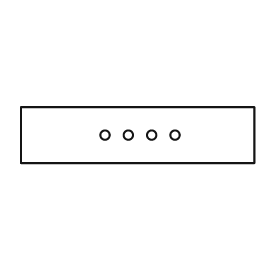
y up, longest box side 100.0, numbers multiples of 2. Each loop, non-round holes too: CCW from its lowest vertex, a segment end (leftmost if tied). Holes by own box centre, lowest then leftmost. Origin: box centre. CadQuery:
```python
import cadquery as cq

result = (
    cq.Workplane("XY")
    .moveTo(-50.0, -12.0)
    .lineTo(50.0, -12.0)
    .lineTo(50.0, 12.0)
    .lineTo(-50.0, 12.0)
    .close()
    .moveTo(-14.0, 0.0)
    .circle(2.0)
    .moveTo(-4.0, 0.0)
    .circle(2.0)
    .moveTo(6.0, 0.0)
    .circle(2.0)
    .moveTo(16.0, 0.0)
    .circle(2.0)
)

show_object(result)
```